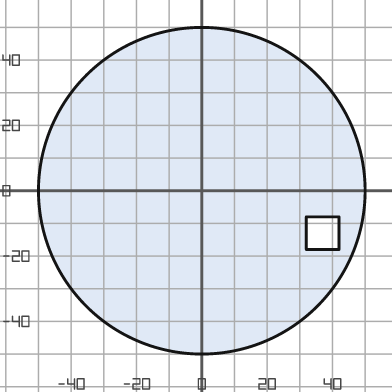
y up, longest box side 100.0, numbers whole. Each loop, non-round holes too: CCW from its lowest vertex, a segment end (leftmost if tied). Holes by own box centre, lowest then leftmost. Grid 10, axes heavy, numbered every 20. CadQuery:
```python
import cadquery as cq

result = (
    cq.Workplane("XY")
    .moveTo(0.0, 0.0)
    .circle(50.0)
    .moveTo(32.0, -18.0)
    .lineTo(42.0, -18.0)
    .lineTo(42.0, -8.0)
    .lineTo(32.0, -8.0)
    .close()
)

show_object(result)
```